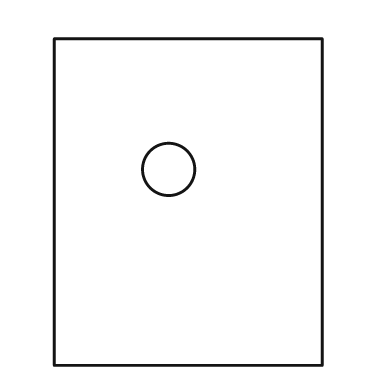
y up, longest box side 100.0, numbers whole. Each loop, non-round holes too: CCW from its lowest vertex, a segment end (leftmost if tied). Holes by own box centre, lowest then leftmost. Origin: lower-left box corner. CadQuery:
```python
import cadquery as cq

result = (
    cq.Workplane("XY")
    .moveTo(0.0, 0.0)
    .lineTo(82.0, 0.0)
    .lineTo(82.0, 100.0)
    .lineTo(0.0, 100.0)
    .close()
    .moveTo(35.0, 60.0)
    .circle(8.0)
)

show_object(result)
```